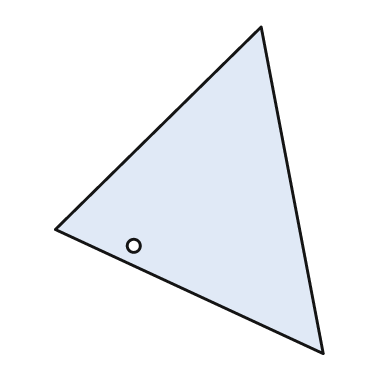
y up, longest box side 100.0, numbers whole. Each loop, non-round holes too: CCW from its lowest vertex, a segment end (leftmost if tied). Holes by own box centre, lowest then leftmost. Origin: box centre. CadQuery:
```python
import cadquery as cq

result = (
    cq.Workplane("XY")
    .moveTo(41.0, -50.0)
    .lineTo(22.0, 50.0)
    .lineTo(-41.0, -12.0)
    .close()
    .moveTo(-17.0, -17.0)
    .circle(2.0)
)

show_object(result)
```